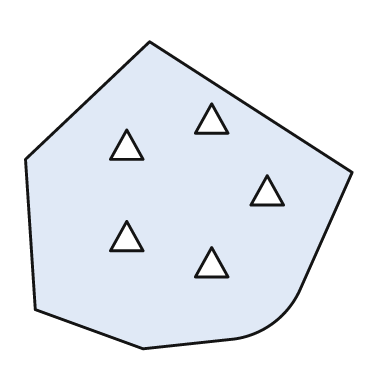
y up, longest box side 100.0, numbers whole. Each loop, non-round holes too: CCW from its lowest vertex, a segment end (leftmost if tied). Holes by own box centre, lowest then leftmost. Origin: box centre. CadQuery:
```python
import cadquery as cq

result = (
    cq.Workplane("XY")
    .moveTo(-14.0, -47.0)
    .lineTo(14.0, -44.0)
    .threePointArc((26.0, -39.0), (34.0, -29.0))
    .lineTo(50.0, 7.0)
    .lineTo(-12.0, 47.0)
    .lineTo(-50.0, 11.0)
    .lineTo(-47.0, -35.0)
    .close()
    .moveTo(2.0, -25.0)
    .lineTo(12.0, -25.0)
    .lineTo(7.0, -16.0)
    .close()
    .moveTo(-24.0, -17.0)
    .lineTo(-14.0, -17.0)
    .lineTo(-19.0, -8.0)
    .close()
    .moveTo(19.0, -3.0)
    .lineTo(29.0, -3.0)
    .lineTo(24.0, 6.0)
    .close()
    .moveTo(-24.0, 11.0)
    .lineTo(-14.0, 11.0)
    .lineTo(-19.0, 20.0)
    .close()
    .moveTo(2.0, 19.0)
    .lineTo(12.0, 19.0)
    .lineTo(7.0, 28.0)
    .close()
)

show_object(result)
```